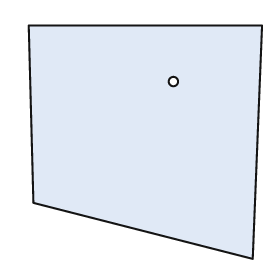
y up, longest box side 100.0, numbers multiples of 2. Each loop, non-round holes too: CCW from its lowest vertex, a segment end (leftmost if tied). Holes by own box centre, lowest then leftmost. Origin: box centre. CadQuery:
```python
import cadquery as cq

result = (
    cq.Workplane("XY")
    .moveTo(46.0, -50.0)
    .lineTo(50.0, 50.0)
    .lineTo(-50.0, 50.0)
    .lineTo(-48.0, -26.0)
    .close()
    .moveTo(12.0, 26.0)
    .circle(2.0)
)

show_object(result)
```